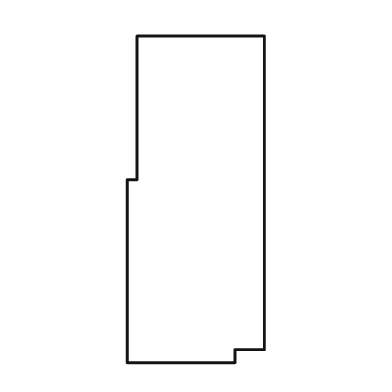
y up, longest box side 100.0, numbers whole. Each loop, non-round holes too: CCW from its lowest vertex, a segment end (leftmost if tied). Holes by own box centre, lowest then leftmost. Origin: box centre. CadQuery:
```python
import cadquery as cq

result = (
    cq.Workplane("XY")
    .moveTo(-21.0, -50.0)
    .lineTo(12.0, -50.0)
    .lineTo(12.0, -46.0)
    .lineTo(21.0, -46.0)
    .lineTo(21.0, 50.0)
    .lineTo(-18.0, 50.0)
    .lineTo(-18.0, 6.0)
    .lineTo(-21.0, 6.0)
    .close()
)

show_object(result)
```